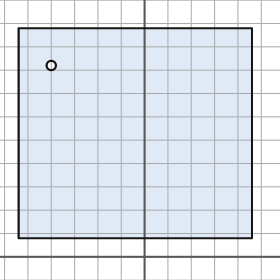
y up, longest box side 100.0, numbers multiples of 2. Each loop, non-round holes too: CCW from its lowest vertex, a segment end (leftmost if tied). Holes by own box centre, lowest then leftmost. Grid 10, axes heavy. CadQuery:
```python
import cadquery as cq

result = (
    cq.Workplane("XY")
    .moveTo(-54.0, 8.0)
    .lineTo(46.0, 8.0)
    .lineTo(46.0, 98.0)
    .lineTo(-54.0, 98.0)
    .close()
    .moveTo(-40.0, 82.0)
    .circle(2.0)
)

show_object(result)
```